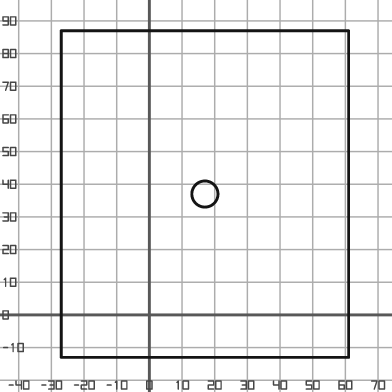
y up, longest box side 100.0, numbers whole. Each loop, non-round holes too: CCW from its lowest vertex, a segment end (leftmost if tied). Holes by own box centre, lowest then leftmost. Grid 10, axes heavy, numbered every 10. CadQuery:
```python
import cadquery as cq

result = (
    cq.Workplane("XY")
    .moveTo(-27.0, -13.0)
    .lineTo(61.0, -13.0)
    .lineTo(61.0, 87.0)
    .lineTo(-27.0, 87.0)
    .close()
    .moveTo(17.0, 37.0)
    .circle(4.0)
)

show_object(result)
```